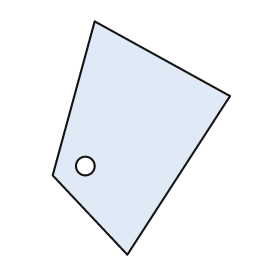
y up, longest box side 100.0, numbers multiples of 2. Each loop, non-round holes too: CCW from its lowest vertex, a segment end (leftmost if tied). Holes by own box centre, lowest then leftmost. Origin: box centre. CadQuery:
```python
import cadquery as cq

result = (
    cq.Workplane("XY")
    .moveTo(-6.0, -50.0)
    .lineTo(38.0, 18.0)
    .lineTo(-20.0, 50.0)
    .lineTo(-38.0, -16.0)
    .close()
    .moveTo(-24.0, -12.0)
    .circle(4.0)
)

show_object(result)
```